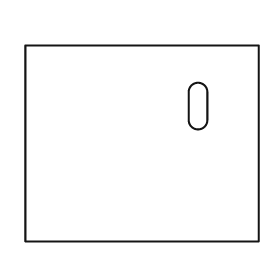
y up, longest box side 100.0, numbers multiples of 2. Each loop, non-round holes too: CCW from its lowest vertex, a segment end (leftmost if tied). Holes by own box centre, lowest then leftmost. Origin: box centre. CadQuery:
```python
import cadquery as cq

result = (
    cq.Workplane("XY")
    .moveTo(-50.0, -42.0)
    .lineTo(50.0, -42.0)
    .lineTo(50.0, 42.0)
    .lineTo(-50.0, 42.0)
    .close()
    .moveTo(20.0, 10.0)
    .threePointArc((24.0, 6.0), (28.0, 10.0))
    .lineTo(28.0, 22.0)
    .threePointArc((24.0, 26.0), (20.0, 22.0))
    .close()
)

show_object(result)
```